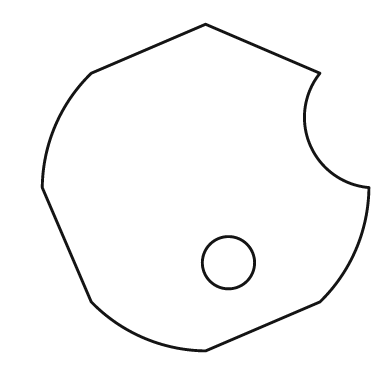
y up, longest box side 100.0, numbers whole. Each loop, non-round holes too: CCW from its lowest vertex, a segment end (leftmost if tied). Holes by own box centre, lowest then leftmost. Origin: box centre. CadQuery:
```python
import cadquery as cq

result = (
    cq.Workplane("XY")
    .moveTo(0.0, -50.0)
    .lineTo(35.0, -35.0)
    .threePointArc((46.0, -19.0), (50.0, 0.0))
    .threePointArc((32.0, 13.0), (35.0, 35.0))
    .lineTo(0.0, 50.0)
    .lineTo(-35.0, 35.0)
    .threePointArc((-46.0, 19.0), (-50.0, 0.0))
    .lineTo(-35.0, -35.0)
    .threePointArc((-19.0, -46.0), (0.0, -50.0))
    .close()
    .moveTo(7.0, -23.0)
    .circle(8.0)
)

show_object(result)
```